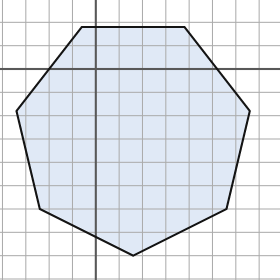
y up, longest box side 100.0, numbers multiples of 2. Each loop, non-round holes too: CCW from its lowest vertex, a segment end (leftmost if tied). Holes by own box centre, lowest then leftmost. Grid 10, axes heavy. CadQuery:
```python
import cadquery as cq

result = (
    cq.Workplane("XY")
    .moveTo(16.0, -80.0)
    .lineTo(56.0, -60.0)
    .lineTo(66.0, -18.0)
    .lineTo(38.0, 18.0)
    .lineTo(-6.0, 18.0)
    .lineTo(-34.0, -18.0)
    .lineTo(-24.0, -60.0)
    .close()
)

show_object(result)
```